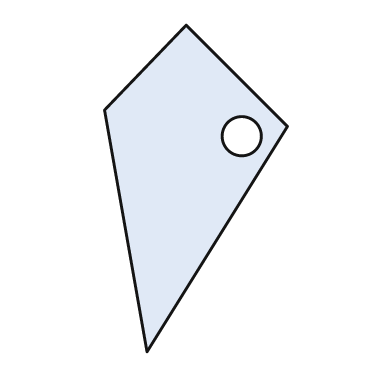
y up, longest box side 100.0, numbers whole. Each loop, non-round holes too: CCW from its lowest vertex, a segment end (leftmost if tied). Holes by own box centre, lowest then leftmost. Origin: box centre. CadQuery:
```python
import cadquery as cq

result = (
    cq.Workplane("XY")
    .moveTo(-15.0, -50.0)
    .lineTo(28.0, 19.0)
    .lineTo(-3.0, 50.0)
    .lineTo(-28.0, 24.0)
    .close()
    .moveTo(14.0, 16.0)
    .circle(6.0)
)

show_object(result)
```